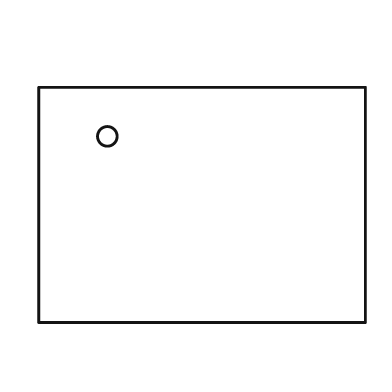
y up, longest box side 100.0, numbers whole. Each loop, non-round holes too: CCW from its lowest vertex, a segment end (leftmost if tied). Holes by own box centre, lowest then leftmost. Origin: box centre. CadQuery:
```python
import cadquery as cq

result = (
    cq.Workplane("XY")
    .moveTo(-50.0, -36.0)
    .lineTo(50.0, -36.0)
    .lineTo(50.0, 36.0)
    .lineTo(-50.0, 36.0)
    .close()
    .moveTo(-29.0, 21.0)
    .circle(3.0)
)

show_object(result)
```